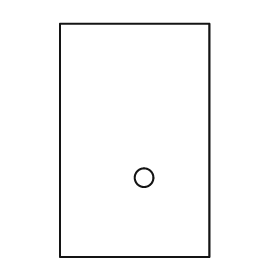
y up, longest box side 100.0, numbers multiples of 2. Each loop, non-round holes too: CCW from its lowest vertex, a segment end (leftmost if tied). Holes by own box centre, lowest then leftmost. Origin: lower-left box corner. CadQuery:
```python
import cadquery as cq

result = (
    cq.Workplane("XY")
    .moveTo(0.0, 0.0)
    .lineTo(64.0, 0.0)
    .lineTo(64.0, 100.0)
    .lineTo(0.0, 100.0)
    .close()
    .moveTo(36.0, 34.0)
    .circle(4.0)
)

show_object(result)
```